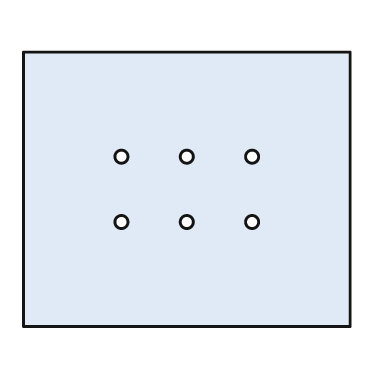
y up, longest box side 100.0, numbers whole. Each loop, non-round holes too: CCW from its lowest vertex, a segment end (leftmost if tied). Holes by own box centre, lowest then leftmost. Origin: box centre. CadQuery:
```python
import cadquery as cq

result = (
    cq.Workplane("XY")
    .moveTo(-50.0, -42.0)
    .lineTo(50.0, -42.0)
    .lineTo(50.0, 42.0)
    .lineTo(-50.0, 42.0)
    .close()
    .moveTo(-20.0, -10.0)
    .circle(2.0)
    .moveTo(0.0, -10.0)
    .circle(2.0)
    .moveTo(20.0, -10.0)
    .circle(2.0)
    .moveTo(-20.0, 10.0)
    .circle(2.0)
    .moveTo(0.0, 10.0)
    .circle(2.0)
    .moveTo(20.0, 10.0)
    .circle(2.0)
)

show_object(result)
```